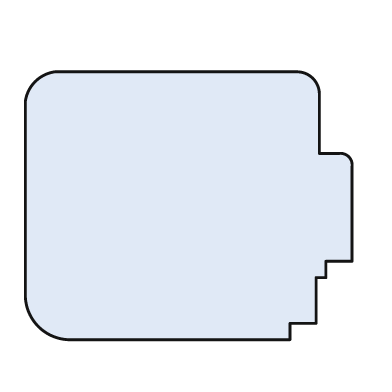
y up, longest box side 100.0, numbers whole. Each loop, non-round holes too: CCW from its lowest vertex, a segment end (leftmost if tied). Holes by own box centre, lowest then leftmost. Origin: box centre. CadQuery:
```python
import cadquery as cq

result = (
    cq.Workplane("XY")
    .moveTo(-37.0, -41.0)
    .lineTo(31.0, -41.0)
    .lineTo(31.0, -36.0)
    .lineTo(39.0, -36.0)
    .lineTo(39.0, -22.0)
    .lineTo(42.0, -22.0)
    .lineTo(42.0, -17.0)
    .lineTo(50.0, -17.0)
    .lineTo(50.0, 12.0)
    .threePointArc((49.0, 15.0), (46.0, 16.0))
    .lineTo(40.0, 16.0)
    .lineTo(40.0, 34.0)
    .threePointArc((38.0, 39.0), (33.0, 41.0))
    .lineTo(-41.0, 41.0)
    .threePointArc((-47.0, 38.0), (-50.0, 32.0))
    .lineTo(-50.0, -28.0)
    .threePointArc((-46.0, -37.0), (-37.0, -41.0))
    .close()
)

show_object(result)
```